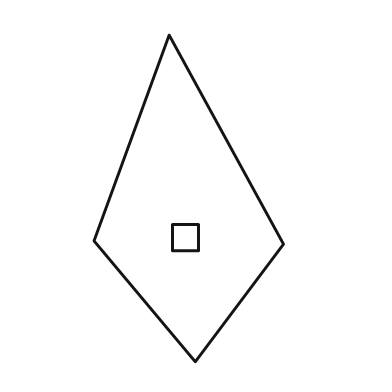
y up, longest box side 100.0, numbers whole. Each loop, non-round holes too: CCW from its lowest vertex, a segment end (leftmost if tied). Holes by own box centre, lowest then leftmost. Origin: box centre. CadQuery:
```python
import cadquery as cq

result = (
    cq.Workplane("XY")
    .moveTo(2.0, -50.0)
    .lineTo(29.0, -14.0)
    .lineTo(-6.0, 50.0)
    .lineTo(-29.0, -13.0)
    .close()
    .moveTo(-5.0, -16.0)
    .lineTo(3.0, -16.0)
    .lineTo(3.0, -8.0)
    .lineTo(-5.0, -8.0)
    .close()
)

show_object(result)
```